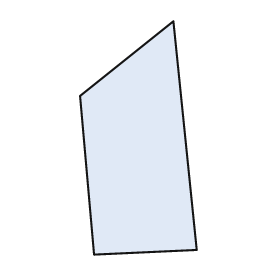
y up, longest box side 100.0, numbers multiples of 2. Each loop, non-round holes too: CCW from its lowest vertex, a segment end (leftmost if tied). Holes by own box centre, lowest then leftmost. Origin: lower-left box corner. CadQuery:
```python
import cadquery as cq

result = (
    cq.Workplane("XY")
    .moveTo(6.0, 0.0)
    .lineTo(50.0, 2.0)
    .lineTo(40.0, 100.0)
    .lineTo(0.0, 68.0)
    .close()
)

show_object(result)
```